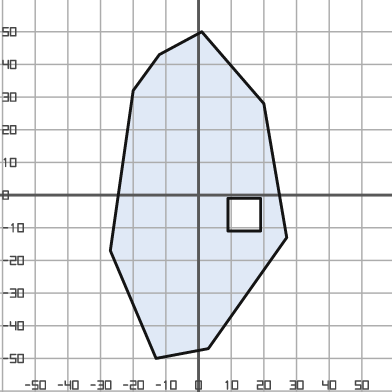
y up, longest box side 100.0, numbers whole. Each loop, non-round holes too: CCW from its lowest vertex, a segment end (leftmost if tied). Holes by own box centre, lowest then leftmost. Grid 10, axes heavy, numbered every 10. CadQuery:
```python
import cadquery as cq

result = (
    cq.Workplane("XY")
    .moveTo(-13.0, -50.0)
    .lineTo(3.0, -47.0)
    .lineTo(27.0, -13.0)
    .lineTo(20.0, 28.0)
    .lineTo(1.0, 50.0)
    .lineTo(-12.0, 43.0)
    .lineTo(-20.0, 32.0)
    .lineTo(-27.0, -17.0)
    .close()
    .moveTo(9.0, -11.0)
    .lineTo(19.0, -11.0)
    .lineTo(19.0, -1.0)
    .lineTo(9.0, -1.0)
    .close()
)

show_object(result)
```